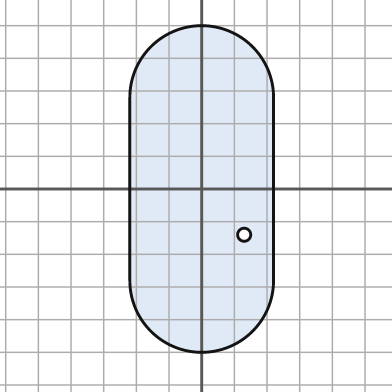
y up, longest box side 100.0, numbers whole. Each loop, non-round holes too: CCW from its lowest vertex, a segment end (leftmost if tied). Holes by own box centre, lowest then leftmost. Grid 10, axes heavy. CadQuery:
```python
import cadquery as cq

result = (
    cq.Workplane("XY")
    .moveTo(-22.0, -28.0)
    .threePointArc((0.0, -50.0), (22.0, -28.0))
    .lineTo(22.0, 28.0)
    .threePointArc((0.0, 50.0), (-22.0, 28.0))
    .close()
    .moveTo(13.0, -14.0)
    .circle(2.0)
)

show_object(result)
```